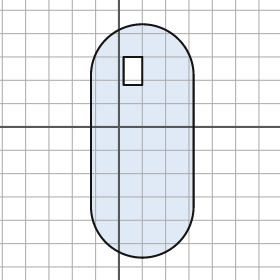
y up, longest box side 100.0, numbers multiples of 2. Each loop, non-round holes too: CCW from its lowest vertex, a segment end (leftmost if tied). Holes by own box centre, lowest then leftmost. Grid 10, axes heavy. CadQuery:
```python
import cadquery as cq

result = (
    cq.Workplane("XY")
    .moveTo(-12.0, -34.0)
    .threePointArc((10.0, -56.0), (32.0, -34.0))
    .lineTo(32.0, 22.0)
    .threePointArc((10.0, 44.0), (-12.0, 22.0))
    .close()
    .moveTo(2.0, 18.0)
    .lineTo(10.0, 18.0)
    .lineTo(10.0, 30.0)
    .lineTo(2.0, 30.0)
    .close()
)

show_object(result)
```